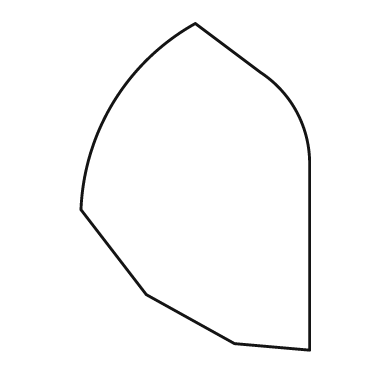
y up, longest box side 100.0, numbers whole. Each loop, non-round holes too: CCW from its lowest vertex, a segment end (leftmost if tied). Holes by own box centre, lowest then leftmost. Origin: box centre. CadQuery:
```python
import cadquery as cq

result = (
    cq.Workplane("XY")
    .moveTo(35.0, -50.0)
    .lineTo(35.0, 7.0)
    .threePointArc((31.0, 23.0), (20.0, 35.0))
    .lineTo(0.0, 50.0)
    .threePointArc((-25.0, 26.0), (-35.0, -7.0))
    .lineTo(-15.0, -33.0)
    .lineTo(12.0, -48.0)
    .close()
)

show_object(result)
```